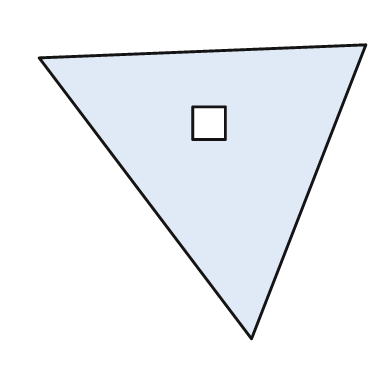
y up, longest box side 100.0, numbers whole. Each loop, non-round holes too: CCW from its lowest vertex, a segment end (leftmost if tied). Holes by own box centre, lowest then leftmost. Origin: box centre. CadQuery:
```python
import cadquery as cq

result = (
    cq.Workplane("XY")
    .moveTo(15.0, -45.0)
    .lineTo(50.0, 45.0)
    .lineTo(-50.0, 41.0)
    .close()
    .moveTo(-3.0, 16.0)
    .lineTo(7.0, 16.0)
    .lineTo(7.0, 26.0)
    .lineTo(-3.0, 26.0)
    .close()
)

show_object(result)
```